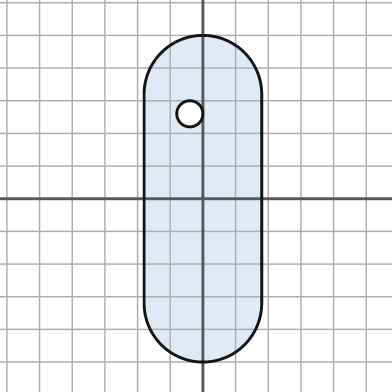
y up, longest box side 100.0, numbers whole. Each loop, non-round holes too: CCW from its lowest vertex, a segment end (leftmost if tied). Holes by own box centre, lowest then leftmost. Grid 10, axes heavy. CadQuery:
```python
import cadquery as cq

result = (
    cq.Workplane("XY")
    .moveTo(-18.0, -32.0)
    .threePointArc((0.0, -50.0), (18.0, -32.0))
    .lineTo(18.0, 32.0)
    .threePointArc((0.0, 50.0), (-18.0, 32.0))
    .close()
    .moveTo(-4.0, 26.0)
    .circle(4.0)
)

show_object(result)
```